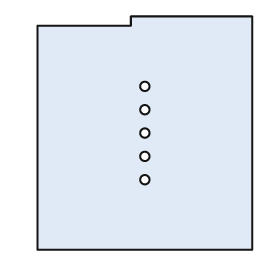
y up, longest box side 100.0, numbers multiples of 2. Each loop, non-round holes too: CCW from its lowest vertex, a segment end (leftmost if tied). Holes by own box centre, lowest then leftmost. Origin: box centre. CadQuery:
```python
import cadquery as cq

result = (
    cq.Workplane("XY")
    .moveTo(-46.0, -50.0)
    .lineTo(46.0, -50.0)
    .lineTo(46.0, 50.0)
    .lineTo(-6.0, 50.0)
    .lineTo(-6.0, 46.0)
    .lineTo(-46.0, 46.0)
    .close()
    .moveTo(0.0, -20.0)
    .circle(2.0)
    .moveTo(0.0, -10.0)
    .circle(2.0)
    .moveTo(0.0, 0.0)
    .circle(2.0)
    .moveTo(0.0, 10.0)
    .circle(2.0)
    .moveTo(0.0, 20.0)
    .circle(2.0)
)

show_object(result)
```